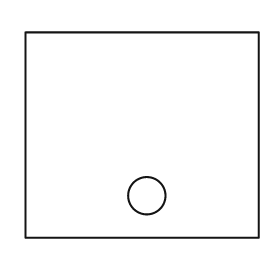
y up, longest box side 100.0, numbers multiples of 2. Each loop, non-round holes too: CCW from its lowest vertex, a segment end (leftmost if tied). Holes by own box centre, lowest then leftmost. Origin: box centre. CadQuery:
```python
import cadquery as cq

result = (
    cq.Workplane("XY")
    .moveTo(-50.0, -44.0)
    .lineTo(50.0, -44.0)
    .lineTo(50.0, 44.0)
    .lineTo(-50.0, 44.0)
    .close()
    .moveTo(2.0, -26.0)
    .circle(8.0)
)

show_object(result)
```